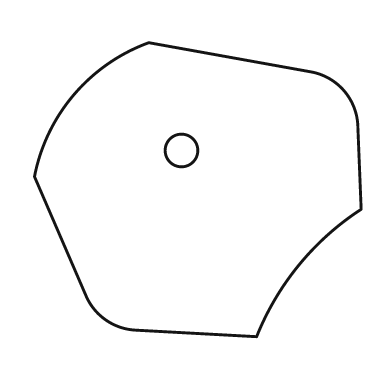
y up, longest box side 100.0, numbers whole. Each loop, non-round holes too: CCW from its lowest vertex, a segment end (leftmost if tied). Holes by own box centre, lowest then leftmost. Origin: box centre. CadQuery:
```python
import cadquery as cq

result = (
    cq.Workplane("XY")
    .moveTo(18.0, -45.0)
    .threePointArc((31.0, -23.0), (50.0, -6.0))
    .lineTo(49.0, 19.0)
    .threePointArc((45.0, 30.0), (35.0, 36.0))
    .lineTo(-15.0, 45.0)
    .threePointArc((-38.0, 29.0), (-50.0, 4.0))
    .lineTo(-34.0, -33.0)
    .threePointArc((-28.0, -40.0), (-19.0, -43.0))
    .close()
    .moveTo(-5.0, 12.0)
    .circle(5.0)
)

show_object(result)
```